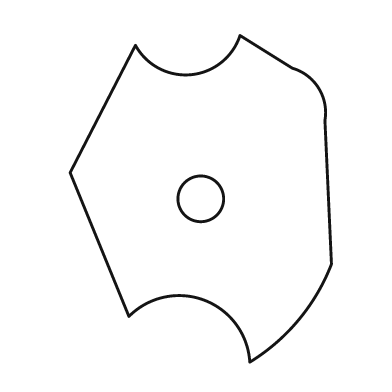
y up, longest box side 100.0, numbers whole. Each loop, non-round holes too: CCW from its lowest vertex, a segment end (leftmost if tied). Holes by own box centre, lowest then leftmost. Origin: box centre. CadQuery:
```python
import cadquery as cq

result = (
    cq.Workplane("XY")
    .moveTo(15.0, -50.0)
    .threePointArc((30.0, -37.0), (40.0, -20.0))
    .lineTo(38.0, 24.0)
    .threePointArc((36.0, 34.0), (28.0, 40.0))
    .lineTo(12.0, 50.0)
    .threePointArc((-3.0, 38.0), (-20.0, 47.0))
    .lineTo(-40.0, 8.0)
    .lineTo(-22.0, -36.0)
    .threePointArc((1.0, -31.0), (15.0, -50.0))
    .close()
    .moveTo(0.0, 0.0)
    .circle(7.0)
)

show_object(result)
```